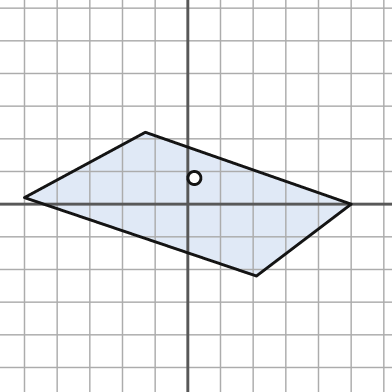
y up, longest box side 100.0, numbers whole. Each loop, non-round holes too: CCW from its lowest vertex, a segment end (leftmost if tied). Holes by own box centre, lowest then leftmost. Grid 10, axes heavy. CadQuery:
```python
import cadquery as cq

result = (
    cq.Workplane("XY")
    .moveTo(21.0, -22.0)
    .lineTo(50.0, 0.0)
    .lineTo(-13.0, 22.0)
    .lineTo(-50.0, 2.0)
    .close()
    .moveTo(2.0, 8.0)
    .circle(2.0)
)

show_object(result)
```